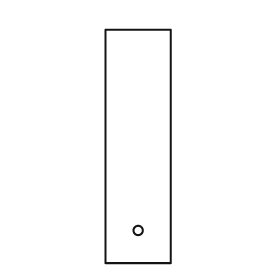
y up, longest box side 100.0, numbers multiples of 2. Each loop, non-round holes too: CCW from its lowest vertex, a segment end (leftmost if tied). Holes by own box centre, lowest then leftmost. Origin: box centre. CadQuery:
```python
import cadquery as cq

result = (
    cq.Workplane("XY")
    .moveTo(-14.0, -50.0)
    .lineTo(14.0, -50.0)
    .lineTo(14.0, 50.0)
    .lineTo(-14.0, 50.0)
    .close()
    .moveTo(0.0, -36.0)
    .circle(2.0)
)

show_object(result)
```